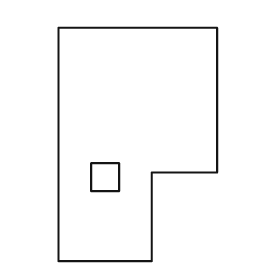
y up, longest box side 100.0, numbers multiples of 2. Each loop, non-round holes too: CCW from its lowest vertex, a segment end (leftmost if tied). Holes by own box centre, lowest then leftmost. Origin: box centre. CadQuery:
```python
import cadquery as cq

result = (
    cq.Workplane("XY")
    .moveTo(-34.0, -50.0)
    .lineTo(6.0, -50.0)
    .lineTo(6.0, -12.0)
    .lineTo(34.0, -12.0)
    .lineTo(34.0, 50.0)
    .lineTo(-34.0, 50.0)
    .close()
    .moveTo(-20.0, -20.0)
    .lineTo(-8.0, -20.0)
    .lineTo(-8.0, -8.0)
    .lineTo(-20.0, -8.0)
    .close()
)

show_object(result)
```